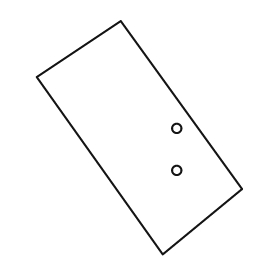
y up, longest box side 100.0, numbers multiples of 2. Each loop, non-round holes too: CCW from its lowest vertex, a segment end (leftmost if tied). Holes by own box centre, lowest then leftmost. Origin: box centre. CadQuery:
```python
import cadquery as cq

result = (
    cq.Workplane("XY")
    .moveTo(10.0, -50.0)
    .lineTo(44.0, -22.0)
    .lineTo(-8.0, 50.0)
    .lineTo(-44.0, 26.0)
    .close()
    .moveTo(16.0, -14.0)
    .circle(2.0)
    .moveTo(16.0, 4.0)
    .circle(2.0)
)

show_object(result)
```